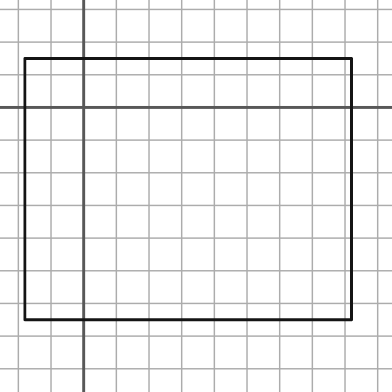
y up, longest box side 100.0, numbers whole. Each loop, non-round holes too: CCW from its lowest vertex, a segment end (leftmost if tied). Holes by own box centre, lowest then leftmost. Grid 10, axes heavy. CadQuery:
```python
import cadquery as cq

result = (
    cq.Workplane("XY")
    .moveTo(-18.0, -65.0)
    .lineTo(82.0, -65.0)
    .lineTo(82.0, 15.0)
    .lineTo(-18.0, 15.0)
    .close()
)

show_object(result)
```